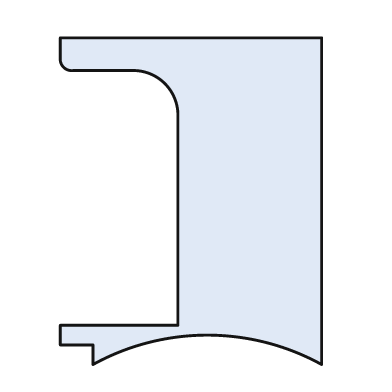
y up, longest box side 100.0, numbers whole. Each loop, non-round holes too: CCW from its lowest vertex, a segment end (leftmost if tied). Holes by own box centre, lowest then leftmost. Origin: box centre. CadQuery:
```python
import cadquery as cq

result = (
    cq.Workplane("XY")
    .moveTo(-30.0, -50.0)
    .threePointArc((5.0, -41.0), (40.0, -50.0))
    .lineTo(40.0, 50.0)
    .lineTo(-40.0, 50.0)
    .lineTo(-40.0, 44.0)
    .threePointArc((-39.0, 41.0), (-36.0, 40.0))
    .lineTo(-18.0, 40.0)
    .threePointArc((-8.0, 36.0), (-4.0, 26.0))
    .lineTo(-4.0, -38.0)
    .lineTo(-40.0, -38.0)
    .lineTo(-40.0, -44.0)
    .lineTo(-30.0, -44.0)
    .close()
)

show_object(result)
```